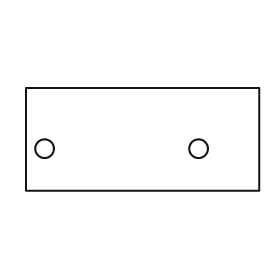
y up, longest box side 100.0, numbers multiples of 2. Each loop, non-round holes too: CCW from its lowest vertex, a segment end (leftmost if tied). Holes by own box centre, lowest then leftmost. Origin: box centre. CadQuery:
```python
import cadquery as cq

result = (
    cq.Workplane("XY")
    .moveTo(-50.0, -22.0)
    .lineTo(50.0, -22.0)
    .lineTo(50.0, 22.0)
    .lineTo(-50.0, 22.0)
    .close()
    .moveTo(-42.0, -4.0)
    .circle(4.0)
    .moveTo(24.0, -4.0)
    .circle(4.0)
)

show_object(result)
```